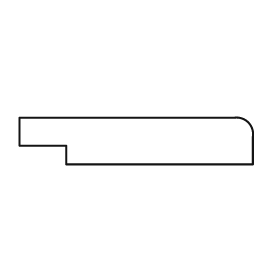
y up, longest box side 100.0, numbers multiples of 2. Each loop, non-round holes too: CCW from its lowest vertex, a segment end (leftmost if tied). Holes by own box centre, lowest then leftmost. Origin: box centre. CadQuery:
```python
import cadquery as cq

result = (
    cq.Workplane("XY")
    .moveTo(-30.0, -10.0)
    .lineTo(50.0, -10.0)
    .lineTo(50.0, 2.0)
    .threePointArc((48.0, 8.0), (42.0, 10.0))
    .lineTo(-50.0, 10.0)
    .lineTo(-50.0, -2.0)
    .lineTo(-30.0, -2.0)
    .close()
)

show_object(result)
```